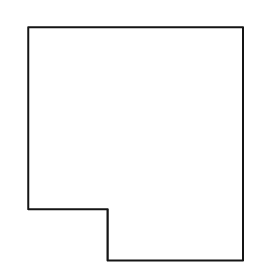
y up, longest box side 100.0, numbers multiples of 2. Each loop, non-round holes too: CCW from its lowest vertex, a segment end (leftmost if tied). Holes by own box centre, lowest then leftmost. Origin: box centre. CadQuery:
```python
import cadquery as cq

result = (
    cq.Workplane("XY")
    .moveTo(-12.0, -50.0)
    .lineTo(46.0, -50.0)
    .lineTo(46.0, 50.0)
    .lineTo(-46.0, 50.0)
    .lineTo(-46.0, -28.0)
    .lineTo(-12.0, -28.0)
    .close()
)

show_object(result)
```